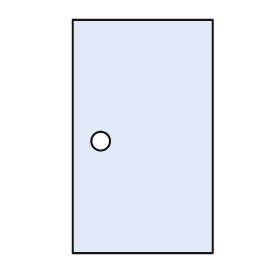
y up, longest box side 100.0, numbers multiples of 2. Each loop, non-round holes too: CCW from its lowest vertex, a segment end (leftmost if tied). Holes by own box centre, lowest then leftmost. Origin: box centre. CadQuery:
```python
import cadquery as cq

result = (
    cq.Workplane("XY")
    .moveTo(-30.0, -50.0)
    .lineTo(30.0, -50.0)
    .lineTo(30.0, 50.0)
    .lineTo(-30.0, 50.0)
    .close()
    .moveTo(-18.0, -2.0)
    .circle(4.0)
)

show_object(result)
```